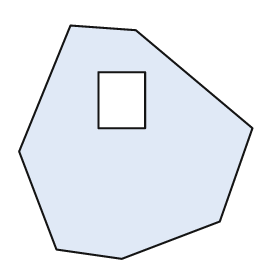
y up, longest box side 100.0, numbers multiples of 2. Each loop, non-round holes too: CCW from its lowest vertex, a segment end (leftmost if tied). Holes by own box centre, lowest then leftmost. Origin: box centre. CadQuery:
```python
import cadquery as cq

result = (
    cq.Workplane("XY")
    .moveTo(-6.0, -50.0)
    .lineTo(36.0, -34.0)
    .lineTo(50.0, 6.0)
    .lineTo(0.0, 48.0)
    .lineTo(-28.0, 50.0)
    .lineTo(-50.0, -4.0)
    .lineTo(-34.0, -46.0)
    .close()
    .moveTo(-16.0, 6.0)
    .lineTo(4.0, 6.0)
    .lineTo(4.0, 30.0)
    .lineTo(-16.0, 30.0)
    .close()
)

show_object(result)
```